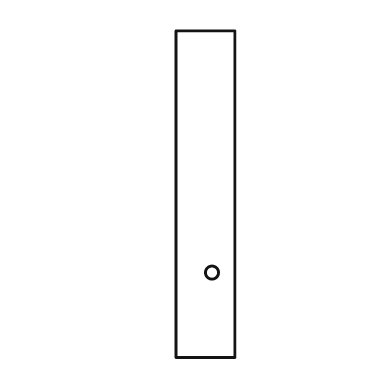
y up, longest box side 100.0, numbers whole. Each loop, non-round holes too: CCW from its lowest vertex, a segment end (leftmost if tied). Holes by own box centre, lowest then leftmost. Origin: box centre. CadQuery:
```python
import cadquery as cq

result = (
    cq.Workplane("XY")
    .moveTo(-9.0, -50.0)
    .lineTo(9.0, -50.0)
    .lineTo(9.0, 50.0)
    .lineTo(-9.0, 50.0)
    .close()
    .moveTo(2.0, -24.0)
    .circle(2.0)
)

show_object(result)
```